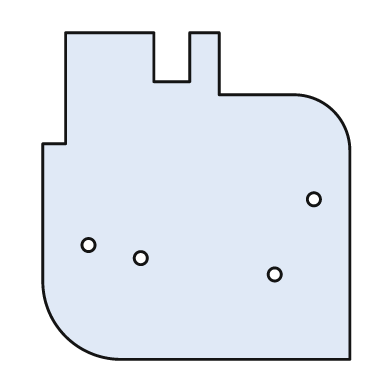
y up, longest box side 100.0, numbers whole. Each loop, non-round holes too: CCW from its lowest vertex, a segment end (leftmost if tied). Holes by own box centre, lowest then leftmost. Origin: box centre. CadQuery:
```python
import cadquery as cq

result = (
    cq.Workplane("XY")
    .moveTo(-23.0, -50.0)
    .lineTo(47.0, -50.0)
    .lineTo(47.0, 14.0)
    .threePointArc((42.0, 26.0), (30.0, 31.0))
    .lineTo(7.0, 31.0)
    .lineTo(7.0, 50.0)
    .lineTo(-2.0, 50.0)
    .lineTo(-2.0, 35.0)
    .lineTo(-13.0, 35.0)
    .lineTo(-13.0, 50.0)
    .lineTo(-40.0, 50.0)
    .lineTo(-40.0, 16.0)
    .lineTo(-47.0, 16.0)
    .lineTo(-47.0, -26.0)
    .threePointArc((-40.0, -43.0), (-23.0, -50.0))
    .close()
    .moveTo(24.0, -24.0)
    .circle(2.0)
    .moveTo(-17.0, -19.0)
    .circle(2.0)
    .moveTo(-33.0, -15.0)
    .circle(2.0)
    .moveTo(36.0, -1.0)
    .circle(2.0)
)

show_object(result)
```